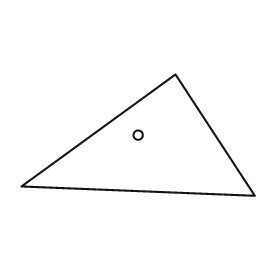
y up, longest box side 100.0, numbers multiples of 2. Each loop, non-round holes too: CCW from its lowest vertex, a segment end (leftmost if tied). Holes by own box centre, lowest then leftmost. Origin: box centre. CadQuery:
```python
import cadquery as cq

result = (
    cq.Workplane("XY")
    .moveTo(50.0, -26.0)
    .lineTo(16.0, 26.0)
    .lineTo(-50.0, -22.0)
    .close()
    .moveTo(0.0, 0.0)
    .circle(2.0)
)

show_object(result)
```